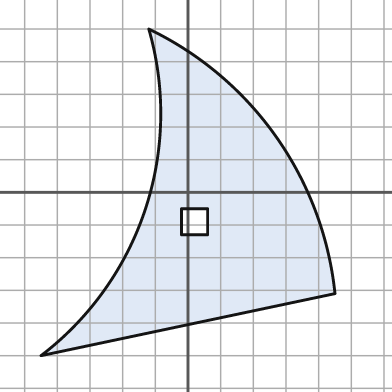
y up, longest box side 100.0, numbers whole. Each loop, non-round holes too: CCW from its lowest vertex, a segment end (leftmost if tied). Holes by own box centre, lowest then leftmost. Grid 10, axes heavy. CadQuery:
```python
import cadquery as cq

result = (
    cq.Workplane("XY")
    .moveTo(-45.0, -50.0)
    .lineTo(45.0, -31.0)
    .threePointArc((27.0, 17.0), (-12.0, 50.0))
    .threePointArc((-13.0, -5.0), (-45.0, -50.0))
    .close()
    .moveTo(-2.0, -13.0)
    .lineTo(6.0, -13.0)
    .lineTo(6.0, -5.0)
    .lineTo(-2.0, -5.0)
    .close()
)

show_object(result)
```